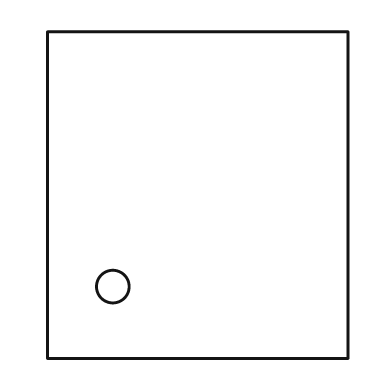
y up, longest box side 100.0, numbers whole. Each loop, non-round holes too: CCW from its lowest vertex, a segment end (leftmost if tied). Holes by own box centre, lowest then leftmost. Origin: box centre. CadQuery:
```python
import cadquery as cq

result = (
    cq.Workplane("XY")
    .moveTo(-46.0, -50.0)
    .lineTo(46.0, -50.0)
    .lineTo(46.0, 50.0)
    .lineTo(-46.0, 50.0)
    .close()
    .moveTo(-26.0, -28.0)
    .circle(5.0)
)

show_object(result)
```